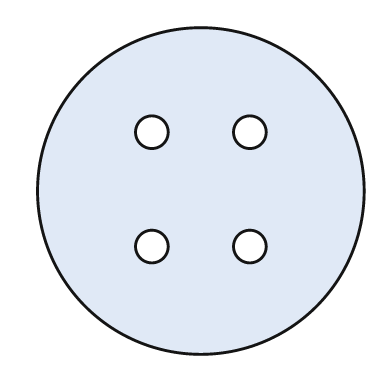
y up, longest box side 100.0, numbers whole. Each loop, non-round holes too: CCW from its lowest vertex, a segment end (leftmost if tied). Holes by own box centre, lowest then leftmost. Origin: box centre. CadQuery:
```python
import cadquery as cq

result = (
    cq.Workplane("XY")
    .moveTo(0.0, 0.0)
    .circle(50.0)
    .moveTo(-15.0, -17.0)
    .circle(5.0)
    .moveTo(15.0, -17.0)
    .circle(5.0)
    .moveTo(-15.0, 18.0)
    .circle(5.0)
    .moveTo(15.0, 18.0)
    .circle(5.0)
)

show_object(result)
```